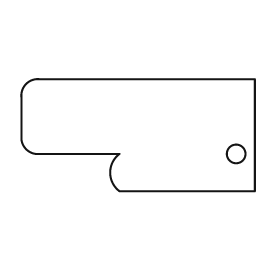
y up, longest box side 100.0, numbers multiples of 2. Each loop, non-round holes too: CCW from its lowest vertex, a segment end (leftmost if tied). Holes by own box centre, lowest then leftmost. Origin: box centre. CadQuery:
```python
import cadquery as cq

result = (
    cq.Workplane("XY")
    .moveTo(-8.0, -24.0)
    .lineTo(50.0, -24.0)
    .lineTo(50.0, 24.0)
    .lineTo(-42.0, 24.0)
    .threePointArc((-48.0, 22.0), (-50.0, 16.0))
    .lineTo(-50.0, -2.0)
    .threePointArc((-48.0, -6.0), (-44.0, -8.0))
    .lineTo(-8.0, -8.0)
    .threePointArc((-12.0, -16.0), (-8.0, -24.0))
    .close()
    .moveTo(42.0, -8.0)
    .circle(4.0)
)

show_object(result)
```